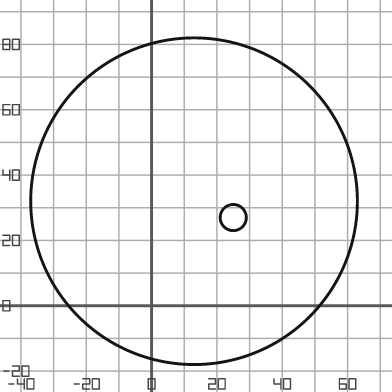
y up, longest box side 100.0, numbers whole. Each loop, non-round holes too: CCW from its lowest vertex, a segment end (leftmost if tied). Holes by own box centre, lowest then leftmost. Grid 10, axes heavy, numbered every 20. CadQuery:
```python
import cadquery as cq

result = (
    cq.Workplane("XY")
    .moveTo(13.0, 32.0)
    .circle(50.0)
    .moveTo(25.0, 27.0)
    .circle(4.0)
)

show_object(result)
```